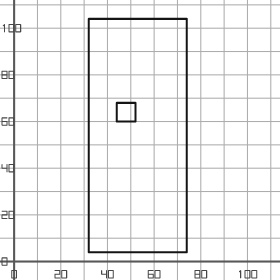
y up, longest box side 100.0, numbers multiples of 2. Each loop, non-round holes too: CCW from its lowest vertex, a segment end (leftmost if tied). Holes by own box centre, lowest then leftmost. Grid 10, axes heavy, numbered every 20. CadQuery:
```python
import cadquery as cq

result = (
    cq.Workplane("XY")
    .moveTo(32.0, 4.0)
    .lineTo(74.0, 4.0)
    .lineTo(74.0, 104.0)
    .lineTo(32.0, 104.0)
    .close()
    .moveTo(44.0, 60.0)
    .lineTo(52.0, 60.0)
    .lineTo(52.0, 68.0)
    .lineTo(44.0, 68.0)
    .close()
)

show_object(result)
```